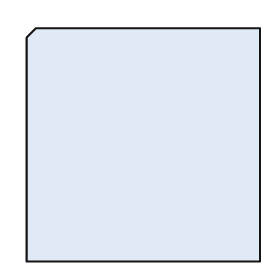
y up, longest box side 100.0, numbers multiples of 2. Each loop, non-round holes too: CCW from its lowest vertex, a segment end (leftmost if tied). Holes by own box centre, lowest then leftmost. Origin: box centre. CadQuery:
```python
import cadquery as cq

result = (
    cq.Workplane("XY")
    .moveTo(-50.0, -50.0)
    .lineTo(50.0, -50.0)
    .lineTo(50.0, 50.0)
    .lineTo(-46.0, 50.0)
    .lineTo(-50.0, 46.0)
    .close()
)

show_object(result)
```